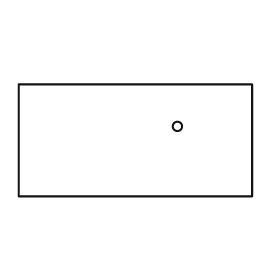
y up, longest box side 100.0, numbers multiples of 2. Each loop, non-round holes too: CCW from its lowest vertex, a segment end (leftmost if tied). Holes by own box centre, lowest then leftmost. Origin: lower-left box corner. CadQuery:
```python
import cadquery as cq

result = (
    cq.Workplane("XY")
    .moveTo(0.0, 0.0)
    .lineTo(100.0, 0.0)
    .lineTo(100.0, 48.0)
    .lineTo(0.0, 48.0)
    .close()
    .moveTo(68.0, 30.0)
    .circle(2.0)
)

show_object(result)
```